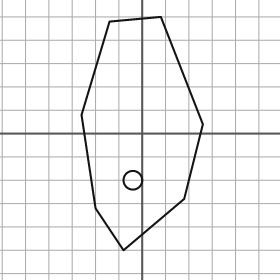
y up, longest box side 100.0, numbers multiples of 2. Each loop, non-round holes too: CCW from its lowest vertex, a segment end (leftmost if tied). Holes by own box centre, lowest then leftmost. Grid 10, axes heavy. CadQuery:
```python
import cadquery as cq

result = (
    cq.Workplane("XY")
    .moveTo(-8.0, -50.0)
    .lineTo(18.0, -28.0)
    .lineTo(26.0, 4.0)
    .lineTo(8.0, 50.0)
    .lineTo(-14.0, 48.0)
    .lineTo(-26.0, 8.0)
    .lineTo(-20.0, -32.0)
    .close()
    .moveTo(-4.0, -20.0)
    .circle(4.0)
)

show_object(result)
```